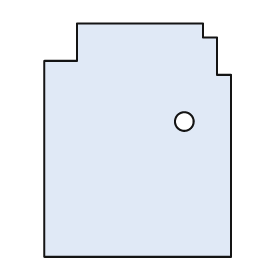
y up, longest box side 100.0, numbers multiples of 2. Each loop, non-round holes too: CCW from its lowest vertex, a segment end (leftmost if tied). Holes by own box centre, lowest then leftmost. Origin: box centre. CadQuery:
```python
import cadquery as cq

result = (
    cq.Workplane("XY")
    .moveTo(-40.0, -50.0)
    .lineTo(40.0, -50.0)
    .lineTo(40.0, 28.0)
    .lineTo(34.0, 28.0)
    .lineTo(34.0, 44.0)
    .lineTo(28.0, 44.0)
    .lineTo(28.0, 50.0)
    .lineTo(-26.0, 50.0)
    .lineTo(-26.0, 34.0)
    .lineTo(-40.0, 34.0)
    .close()
    .moveTo(20.0, 8.0)
    .circle(4.0)
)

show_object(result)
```